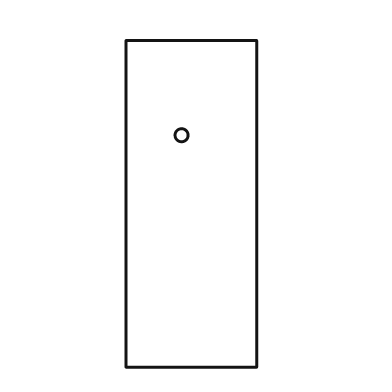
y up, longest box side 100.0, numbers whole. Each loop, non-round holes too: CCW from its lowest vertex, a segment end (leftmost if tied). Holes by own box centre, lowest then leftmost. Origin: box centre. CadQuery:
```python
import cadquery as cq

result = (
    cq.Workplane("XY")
    .moveTo(-20.0, -50.0)
    .lineTo(20.0, -50.0)
    .lineTo(20.0, 50.0)
    .lineTo(-20.0, 50.0)
    .close()
    .moveTo(-3.0, 21.0)
    .circle(2.0)
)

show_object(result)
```